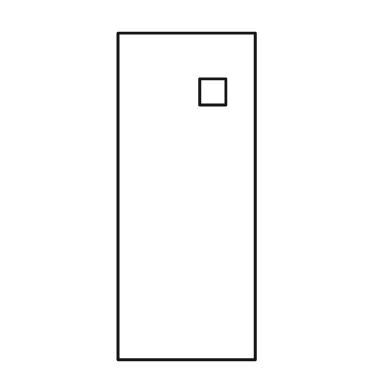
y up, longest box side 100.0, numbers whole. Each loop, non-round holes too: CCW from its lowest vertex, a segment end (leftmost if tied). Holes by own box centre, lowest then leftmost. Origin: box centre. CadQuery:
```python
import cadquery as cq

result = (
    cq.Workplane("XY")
    .moveTo(-21.0, -50.0)
    .lineTo(21.0, -50.0)
    .lineTo(21.0, 50.0)
    .lineTo(-21.0, 50.0)
    .close()
    .moveTo(4.0, 28.0)
    .lineTo(12.0, 28.0)
    .lineTo(12.0, 36.0)
    .lineTo(4.0, 36.0)
    .close()
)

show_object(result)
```